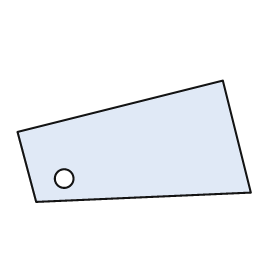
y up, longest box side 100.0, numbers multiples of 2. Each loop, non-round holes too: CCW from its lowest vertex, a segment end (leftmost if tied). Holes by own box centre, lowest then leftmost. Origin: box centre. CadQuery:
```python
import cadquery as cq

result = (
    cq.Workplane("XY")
    .moveTo(-42.0, -26.0)
    .lineTo(50.0, -22.0)
    .lineTo(38.0, 26.0)
    .lineTo(-50.0, 4.0)
    .close()
    .moveTo(-30.0, -16.0)
    .circle(4.0)
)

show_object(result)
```